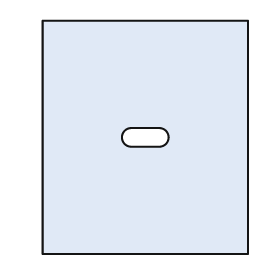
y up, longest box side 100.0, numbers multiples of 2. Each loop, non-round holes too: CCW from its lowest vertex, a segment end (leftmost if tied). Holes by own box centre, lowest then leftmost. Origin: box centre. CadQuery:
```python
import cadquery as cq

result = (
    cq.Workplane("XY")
    .moveTo(-44.0, -50.0)
    .lineTo(44.0, -50.0)
    .lineTo(44.0, 50.0)
    .lineTo(-44.0, 50.0)
    .close()
    .moveTo(-6.0, -4.0)
    .lineTo(6.0, -4.0)
    .threePointArc((10.0, 0.0), (6.0, 4.0))
    .lineTo(-6.0, 4.0)
    .threePointArc((-10.0, 0.0), (-6.0, -4.0))
    .close()
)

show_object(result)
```